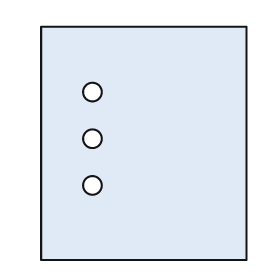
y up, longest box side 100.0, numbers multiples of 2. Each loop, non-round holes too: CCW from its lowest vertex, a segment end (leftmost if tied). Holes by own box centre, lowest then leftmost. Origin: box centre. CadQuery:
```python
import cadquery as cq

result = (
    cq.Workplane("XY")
    .moveTo(-44.0, -50.0)
    .lineTo(44.0, -50.0)
    .lineTo(44.0, 50.0)
    .lineTo(-44.0, 50.0)
    .close()
    .moveTo(-22.0, -18.0)
    .circle(4.0)
    .moveTo(-22.0, 2.0)
    .circle(4.0)
    .moveTo(-22.0, 22.0)
    .circle(4.0)
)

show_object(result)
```